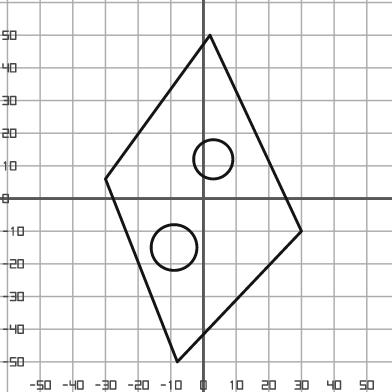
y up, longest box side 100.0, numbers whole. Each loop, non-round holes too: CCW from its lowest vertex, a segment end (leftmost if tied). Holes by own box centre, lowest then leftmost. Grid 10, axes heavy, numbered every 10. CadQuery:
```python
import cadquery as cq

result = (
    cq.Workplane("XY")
    .moveTo(-8.0, -50.0)
    .lineTo(30.0, -10.0)
    .lineTo(2.0, 50.0)
    .lineTo(-30.0, 6.0)
    .close()
    .moveTo(-9.0, -15.0)
    .circle(7.0)
    .moveTo(3.0, 12.0)
    .circle(6.0)
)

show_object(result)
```